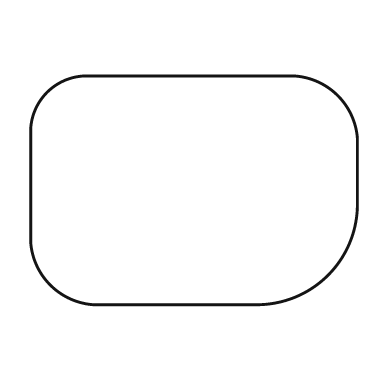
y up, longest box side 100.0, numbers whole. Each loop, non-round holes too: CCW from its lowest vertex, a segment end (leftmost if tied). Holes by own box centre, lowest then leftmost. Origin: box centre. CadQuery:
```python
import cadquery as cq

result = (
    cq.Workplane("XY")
    .moveTo(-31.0, -35.0)
    .lineTo(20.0, -35.0)
    .threePointArc((41.0, -26.0), (50.0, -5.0))
    .lineTo(50.0, 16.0)
    .threePointArc((44.0, 29.0), (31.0, 35.0))
    .lineTo(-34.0, 35.0)
    .threePointArc((-45.0, 30.0), (-50.0, 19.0))
    .lineTo(-50.0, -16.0)
    .threePointArc((-44.0, -29.0), (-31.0, -35.0))
    .close()
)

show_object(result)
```